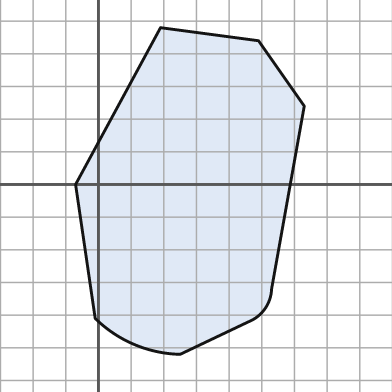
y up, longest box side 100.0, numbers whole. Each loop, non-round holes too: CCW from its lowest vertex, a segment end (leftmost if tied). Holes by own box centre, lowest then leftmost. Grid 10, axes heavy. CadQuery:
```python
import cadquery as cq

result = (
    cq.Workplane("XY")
    .moveTo(25.0, -52.0)
    .lineTo(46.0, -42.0)
    .threePointArc((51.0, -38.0), (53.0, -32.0))
    .lineTo(63.0, 24.0)
    .lineTo(49.0, 44.0)
    .lineTo(19.0, 48.0)
    .lineTo(-7.0, 0.0)
    .lineTo(-1.0, -41.0)
    .threePointArc((11.0, -49.0), (25.0, -52.0))
    .close()
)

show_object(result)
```